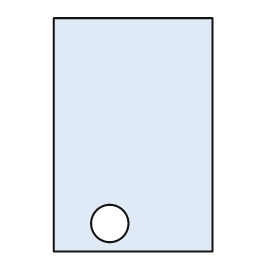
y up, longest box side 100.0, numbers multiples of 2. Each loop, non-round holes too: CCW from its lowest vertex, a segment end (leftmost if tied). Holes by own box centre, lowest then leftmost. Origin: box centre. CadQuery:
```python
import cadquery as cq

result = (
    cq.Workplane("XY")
    .moveTo(-34.0, -50.0)
    .lineTo(34.0, -50.0)
    .lineTo(34.0, 50.0)
    .lineTo(-34.0, 50.0)
    .close()
    .moveTo(-10.0, -38.0)
    .circle(8.0)
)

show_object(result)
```